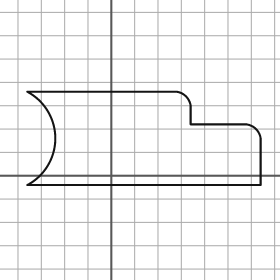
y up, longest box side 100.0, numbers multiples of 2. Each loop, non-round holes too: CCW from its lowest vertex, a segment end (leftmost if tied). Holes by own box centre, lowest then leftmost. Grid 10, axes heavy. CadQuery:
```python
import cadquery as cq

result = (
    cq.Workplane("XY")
    .moveTo(-36.0, -4.0)
    .lineTo(64.0, -4.0)
    .lineTo(64.0, 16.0)
    .threePointArc((62.0, 20.0), (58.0, 22.0))
    .lineTo(34.0, 22.0)
    .lineTo(34.0, 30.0)
    .threePointArc((32.0, 34.0), (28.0, 36.0))
    .lineTo(-36.0, 36.0)
    .threePointArc((-24.0, 16.0), (-36.0, -4.0))
    .close()
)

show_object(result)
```